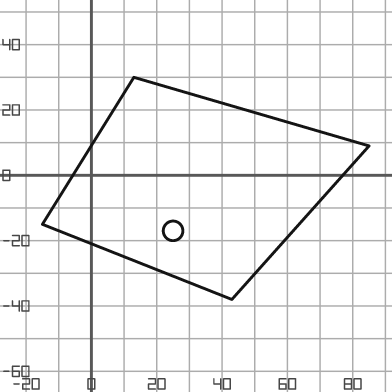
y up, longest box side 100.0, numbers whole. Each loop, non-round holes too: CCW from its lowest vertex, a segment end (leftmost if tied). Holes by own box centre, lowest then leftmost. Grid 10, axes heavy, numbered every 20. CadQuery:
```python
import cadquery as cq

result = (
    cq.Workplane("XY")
    .moveTo(43.0, -38.0)
    .lineTo(85.0, 9.0)
    .lineTo(13.0, 30.0)
    .lineTo(-15.0, -15.0)
    .close()
    .moveTo(25.0, -17.0)
    .circle(3.0)
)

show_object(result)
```